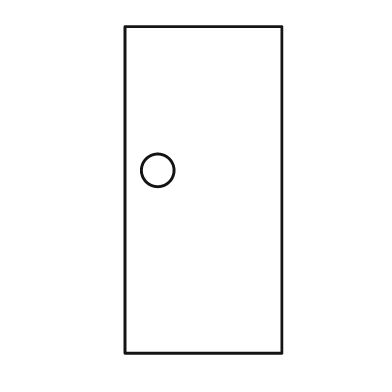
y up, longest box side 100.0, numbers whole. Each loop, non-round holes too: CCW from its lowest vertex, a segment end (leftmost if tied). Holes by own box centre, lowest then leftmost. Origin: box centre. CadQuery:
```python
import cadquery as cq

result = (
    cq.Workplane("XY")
    .moveTo(-24.0, -50.0)
    .lineTo(24.0, -50.0)
    .lineTo(24.0, 50.0)
    .lineTo(-24.0, 50.0)
    .close()
    .moveTo(-14.0, 6.0)
    .circle(5.0)
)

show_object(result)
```